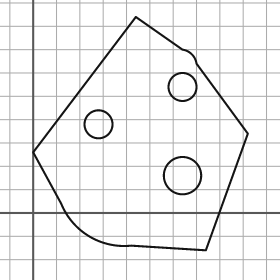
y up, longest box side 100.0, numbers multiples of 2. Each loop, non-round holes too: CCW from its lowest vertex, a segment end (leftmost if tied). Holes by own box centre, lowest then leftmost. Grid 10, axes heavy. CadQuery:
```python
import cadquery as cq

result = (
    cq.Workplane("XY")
    .moveTo(74.0, -16.0)
    .lineTo(92.0, 34.0)
    .lineTo(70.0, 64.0)
    .threePointArc((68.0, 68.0), (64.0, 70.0))
    .lineTo(44.0, 84.0)
    .lineTo(0.0, 26.0)
    .lineTo(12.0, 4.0)
    .threePointArc((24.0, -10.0), (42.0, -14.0))
    .close()
    .moveTo(64.0, 16.0)
    .circle(8.0)
    .moveTo(28.0, 38.0)
    .circle(6.0)
    .moveTo(64.0, 54.0)
    .circle(6.0)
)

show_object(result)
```